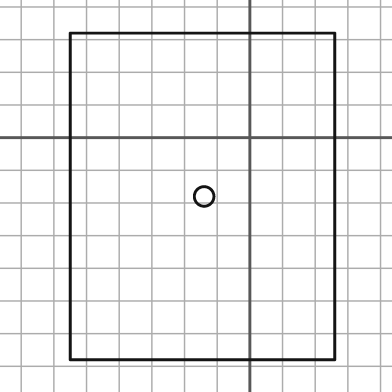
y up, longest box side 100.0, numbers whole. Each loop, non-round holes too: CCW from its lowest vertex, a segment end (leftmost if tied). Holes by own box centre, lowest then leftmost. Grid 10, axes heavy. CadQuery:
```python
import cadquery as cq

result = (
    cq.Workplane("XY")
    .moveTo(-55.0, -68.0)
    .lineTo(26.0, -68.0)
    .lineTo(26.0, 32.0)
    .lineTo(-55.0, 32.0)
    .close()
    .moveTo(-14.0, -18.0)
    .circle(3.0)
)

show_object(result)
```